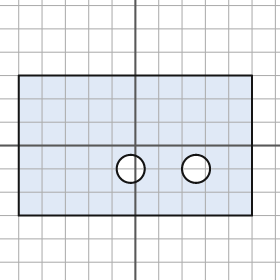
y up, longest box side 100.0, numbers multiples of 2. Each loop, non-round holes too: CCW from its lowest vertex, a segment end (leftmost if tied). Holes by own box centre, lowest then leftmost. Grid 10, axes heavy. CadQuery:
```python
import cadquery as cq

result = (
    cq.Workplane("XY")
    .moveTo(-50.0, -30.0)
    .lineTo(50.0, -30.0)
    .lineTo(50.0, 30.0)
    .lineTo(-50.0, 30.0)
    .close()
    .moveTo(-2.0, -10.0)
    .circle(6.0)
    .moveTo(26.0, -10.0)
    .circle(6.0)
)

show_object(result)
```